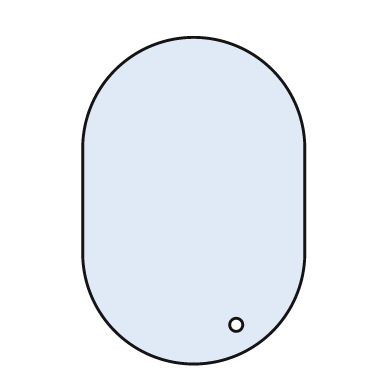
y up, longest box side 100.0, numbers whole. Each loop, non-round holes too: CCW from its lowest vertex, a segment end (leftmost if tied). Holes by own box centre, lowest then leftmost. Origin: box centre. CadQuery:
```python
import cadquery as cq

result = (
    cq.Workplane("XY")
    .moveTo(-34.0, -16.0)
    .threePointArc((0.0, -50.0), (34.0, -16.0))
    .lineTo(34.0, 16.0)
    .threePointArc((0.0, 50.0), (-34.0, 16.0))
    .close()
    .moveTo(13.0, -38.0)
    .circle(2.0)
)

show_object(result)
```